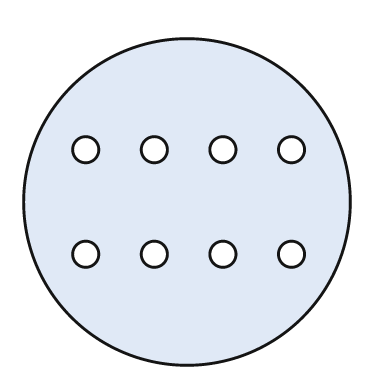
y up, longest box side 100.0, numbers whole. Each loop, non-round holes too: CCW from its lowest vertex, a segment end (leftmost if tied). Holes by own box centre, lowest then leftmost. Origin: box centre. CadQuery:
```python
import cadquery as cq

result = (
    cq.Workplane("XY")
    .moveTo(0.0, 0.0)
    .circle(50.0)
    .moveTo(-31.0, -16.0)
    .circle(4.0)
    .moveTo(-10.0, -16.0)
    .circle(4.0)
    .moveTo(11.0, -16.0)
    .circle(4.0)
    .moveTo(32.0, -16.0)
    .circle(4.0)
    .moveTo(-31.0, 16.0)
    .circle(4.0)
    .moveTo(-10.0, 16.0)
    .circle(4.0)
    .moveTo(11.0, 16.0)
    .circle(4.0)
    .moveTo(32.0, 16.0)
    .circle(4.0)
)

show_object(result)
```